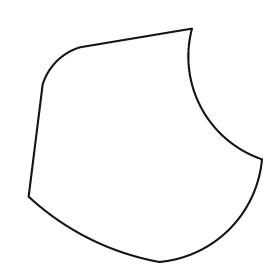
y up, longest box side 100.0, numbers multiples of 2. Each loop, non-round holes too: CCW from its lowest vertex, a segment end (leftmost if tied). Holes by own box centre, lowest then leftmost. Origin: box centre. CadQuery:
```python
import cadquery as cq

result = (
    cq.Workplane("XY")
    .moveTo(6.0, -50.0)
    .threePointArc((36.0, -36.0), (50.0, -6.0))
    .threePointArc((24.0, 16.0), (20.0, 50.0))
    .lineTo(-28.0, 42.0)
    .threePointArc((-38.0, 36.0), (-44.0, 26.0))
    .lineTo(-50.0, -22.0)
    .threePointArc((-24.0, -40.0), (6.0, -50.0))
    .close()
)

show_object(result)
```